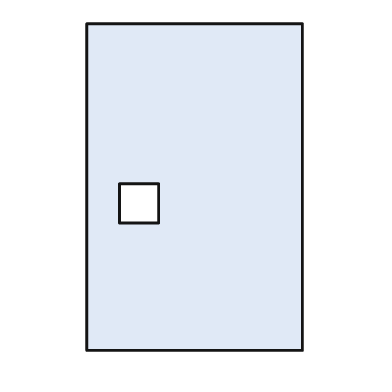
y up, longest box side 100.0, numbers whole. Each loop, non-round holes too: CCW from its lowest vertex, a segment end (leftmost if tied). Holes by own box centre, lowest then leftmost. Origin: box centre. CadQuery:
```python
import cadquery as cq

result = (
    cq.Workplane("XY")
    .moveTo(-33.0, -50.0)
    .lineTo(33.0, -50.0)
    .lineTo(33.0, 50.0)
    .lineTo(-33.0, 50.0)
    .close()
    .moveTo(-23.0, -11.0)
    .lineTo(-11.0, -11.0)
    .lineTo(-11.0, 1.0)
    .lineTo(-23.0, 1.0)
    .close()
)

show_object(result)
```